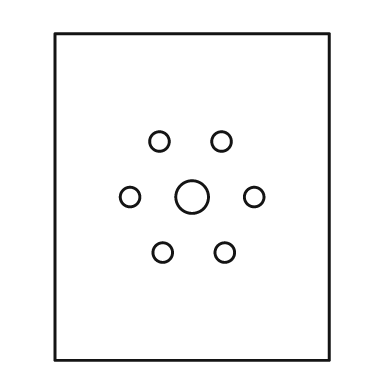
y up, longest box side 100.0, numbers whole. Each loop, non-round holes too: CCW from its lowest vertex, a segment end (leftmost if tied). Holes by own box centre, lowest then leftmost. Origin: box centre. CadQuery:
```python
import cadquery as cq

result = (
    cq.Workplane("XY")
    .moveTo(-42.0, -50.0)
    .lineTo(42.0, -50.0)
    .lineTo(42.0, 50.0)
    .lineTo(-42.0, 50.0)
    .close()
    .moveTo(-9.0, -17.0)
    .circle(3.0)
    .moveTo(10.0, -17.0)
    .circle(3.0)
    .moveTo(-19.0, 0.0)
    .circle(3.0)
    .moveTo(0.0, 0.0)
    .circle(5.0)
    .moveTo(19.0, 0.0)
    .circle(3.0)
    .moveTo(-10.0, 17.0)
    .circle(3.0)
    .moveTo(9.0, 17.0)
    .circle(3.0)
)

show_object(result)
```